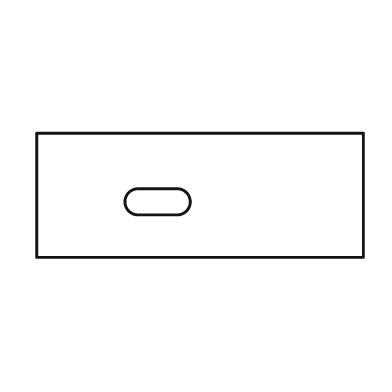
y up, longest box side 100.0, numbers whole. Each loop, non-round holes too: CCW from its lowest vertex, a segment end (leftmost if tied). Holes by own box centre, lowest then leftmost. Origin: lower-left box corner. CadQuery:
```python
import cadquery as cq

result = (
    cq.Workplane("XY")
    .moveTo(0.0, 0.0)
    .lineTo(100.0, 0.0)
    .lineTo(100.0, 38.0)
    .lineTo(0.0, 38.0)
    .close()
    .moveTo(31.0, 13.0)
    .lineTo(43.0, 13.0)
    .threePointArc((47.0, 17.0), (43.0, 21.0))
    .lineTo(31.0, 21.0)
    .threePointArc((27.0, 17.0), (31.0, 13.0))
    .close()
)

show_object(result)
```